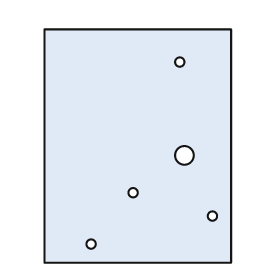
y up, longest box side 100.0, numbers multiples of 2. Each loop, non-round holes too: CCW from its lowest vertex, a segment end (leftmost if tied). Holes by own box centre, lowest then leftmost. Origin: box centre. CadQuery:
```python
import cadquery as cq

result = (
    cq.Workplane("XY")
    .moveTo(-40.0, -50.0)
    .lineTo(40.0, -50.0)
    .lineTo(40.0, 50.0)
    .lineTo(-40.0, 50.0)
    .close()
    .moveTo(-20.0, -42.0)
    .circle(2.0)
    .moveTo(32.0, -30.0)
    .circle(2.0)
    .moveTo(-2.0, -20.0)
    .circle(2.0)
    .moveTo(20.0, -4.0)
    .circle(4.0)
    .moveTo(18.0, 36.0)
    .circle(2.0)
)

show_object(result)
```